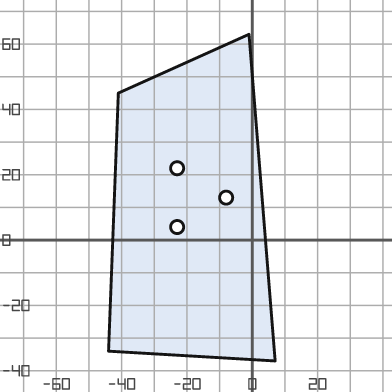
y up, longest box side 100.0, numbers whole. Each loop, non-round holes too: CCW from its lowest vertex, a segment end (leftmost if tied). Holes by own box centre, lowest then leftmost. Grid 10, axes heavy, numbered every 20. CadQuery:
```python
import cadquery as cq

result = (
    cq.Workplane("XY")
    .moveTo(7.0, -37.0)
    .lineTo(-1.0, 63.0)
    .lineTo(-41.0, 45.0)
    .lineTo(-44.0, -34.0)
    .close()
    .moveTo(-23.0, 4.0)
    .circle(2.0)
    .moveTo(-8.0, 13.0)
    .circle(2.0)
    .moveTo(-23.0, 22.0)
    .circle(2.0)
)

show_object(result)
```